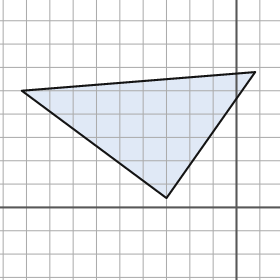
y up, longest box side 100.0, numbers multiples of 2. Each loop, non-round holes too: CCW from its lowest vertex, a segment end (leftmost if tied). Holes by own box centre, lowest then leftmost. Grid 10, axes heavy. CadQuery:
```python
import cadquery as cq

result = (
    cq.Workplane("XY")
    .moveTo(-30.0, 4.0)
    .lineTo(8.0, 58.0)
    .lineTo(-92.0, 50.0)
    .close()
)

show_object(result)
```